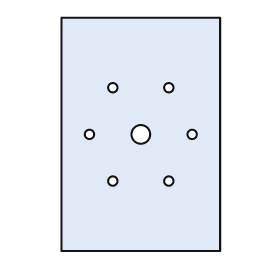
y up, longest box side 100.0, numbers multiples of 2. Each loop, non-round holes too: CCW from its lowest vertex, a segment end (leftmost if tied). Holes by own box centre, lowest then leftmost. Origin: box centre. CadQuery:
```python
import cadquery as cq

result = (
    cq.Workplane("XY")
    .moveTo(-34.0, -50.0)
    .lineTo(34.0, -50.0)
    .lineTo(34.0, 50.0)
    .lineTo(-34.0, 50.0)
    .close()
    .moveTo(-12.0, -20.0)
    .circle(2.0)
    .moveTo(12.0, -20.0)
    .circle(2.0)
    .moveTo(-22.0, 0.0)
    .circle(2.0)
    .moveTo(0.0, 0.0)
    .circle(4.0)
    .moveTo(22.0, 0.0)
    .circle(2.0)
    .moveTo(-12.0, 20.0)
    .circle(2.0)
    .moveTo(12.0, 20.0)
    .circle(2.0)
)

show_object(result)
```